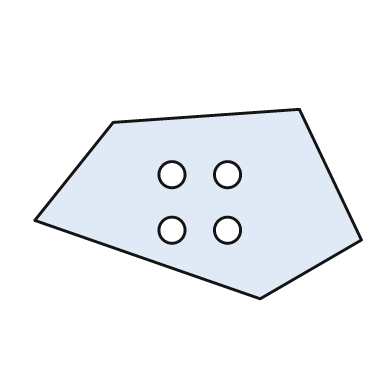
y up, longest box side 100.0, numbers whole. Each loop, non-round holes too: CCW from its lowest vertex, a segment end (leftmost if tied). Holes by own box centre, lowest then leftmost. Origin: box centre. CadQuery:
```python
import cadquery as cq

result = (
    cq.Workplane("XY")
    .moveTo(19.0, -29.0)
    .lineTo(50.0, -11.0)
    .lineTo(31.0, 29.0)
    .lineTo(-26.0, 25.0)
    .lineTo(-50.0, -5.0)
    .close()
    .moveTo(-8.0, -8.0)
    .circle(4.0)
    .moveTo(9.0, -8.0)
    .circle(4.0)
    .moveTo(-8.0, 9.0)
    .circle(4.0)
    .moveTo(9.0, 9.0)
    .circle(4.0)
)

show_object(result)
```